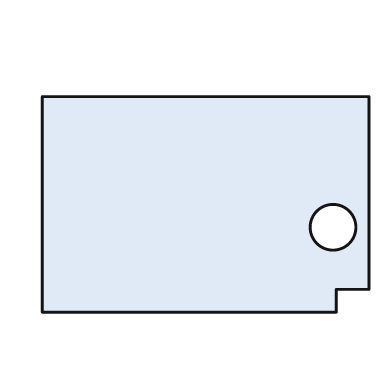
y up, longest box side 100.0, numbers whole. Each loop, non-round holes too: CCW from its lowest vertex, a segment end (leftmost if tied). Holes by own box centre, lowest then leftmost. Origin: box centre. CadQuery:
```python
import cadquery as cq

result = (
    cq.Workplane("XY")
    .moveTo(-50.0, -33.0)
    .lineTo(40.0, -33.0)
    .lineTo(40.0, -26.0)
    .lineTo(50.0, -26.0)
    .lineTo(50.0, 33.0)
    .lineTo(-50.0, 33.0)
    .close()
    .moveTo(39.0, -7.0)
    .circle(7.0)
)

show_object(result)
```